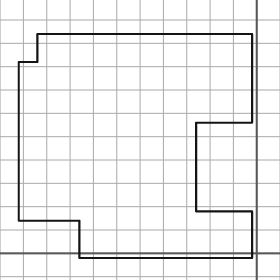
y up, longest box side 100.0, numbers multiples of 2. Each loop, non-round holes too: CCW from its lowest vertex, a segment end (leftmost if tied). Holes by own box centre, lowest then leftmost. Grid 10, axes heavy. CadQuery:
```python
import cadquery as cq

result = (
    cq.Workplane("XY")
    .moveTo(-76.0, -2.0)
    .lineTo(-2.0, -2.0)
    .lineTo(-2.0, 18.0)
    .lineTo(-26.0, 18.0)
    .lineTo(-26.0, 56.0)
    .lineTo(-2.0, 56.0)
    .lineTo(-2.0, 94.0)
    .lineTo(-94.0, 94.0)
    .lineTo(-94.0, 82.0)
    .lineTo(-102.0, 82.0)
    .lineTo(-102.0, 14.0)
    .lineTo(-76.0, 14.0)
    .close()
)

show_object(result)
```